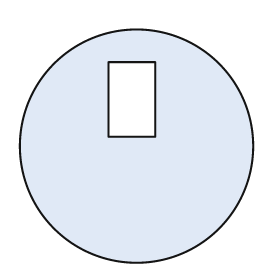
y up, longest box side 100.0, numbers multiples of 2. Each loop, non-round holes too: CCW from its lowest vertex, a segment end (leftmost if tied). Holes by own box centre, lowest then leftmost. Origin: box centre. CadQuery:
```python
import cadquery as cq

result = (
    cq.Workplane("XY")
    .moveTo(0.0, 0.0)
    .circle(50.0)
    .moveTo(-12.0, 4.0)
    .lineTo(8.0, 4.0)
    .lineTo(8.0, 36.0)
    .lineTo(-12.0, 36.0)
    .close()
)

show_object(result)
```